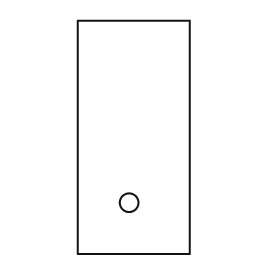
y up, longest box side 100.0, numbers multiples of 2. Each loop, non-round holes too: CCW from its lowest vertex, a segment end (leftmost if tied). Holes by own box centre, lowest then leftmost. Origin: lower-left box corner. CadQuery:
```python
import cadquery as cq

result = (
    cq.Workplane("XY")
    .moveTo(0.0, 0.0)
    .lineTo(48.0, 0.0)
    .lineTo(48.0, 100.0)
    .lineTo(0.0, 100.0)
    .close()
    .moveTo(22.0, 22.0)
    .circle(4.0)
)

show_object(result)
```